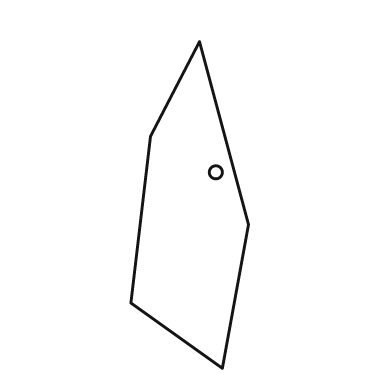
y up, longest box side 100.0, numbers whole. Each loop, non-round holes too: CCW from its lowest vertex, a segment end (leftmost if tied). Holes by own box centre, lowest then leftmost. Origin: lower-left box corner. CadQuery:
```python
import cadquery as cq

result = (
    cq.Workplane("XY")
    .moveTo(28.0, 0.0)
    .lineTo(36.0, 44.0)
    .lineTo(21.0, 100.0)
    .lineTo(6.0, 71.0)
    .lineTo(0.0, 20.0)
    .close()
    .moveTo(26.0, 60.0)
    .circle(2.0)
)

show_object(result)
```